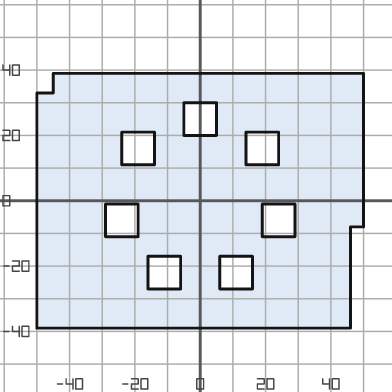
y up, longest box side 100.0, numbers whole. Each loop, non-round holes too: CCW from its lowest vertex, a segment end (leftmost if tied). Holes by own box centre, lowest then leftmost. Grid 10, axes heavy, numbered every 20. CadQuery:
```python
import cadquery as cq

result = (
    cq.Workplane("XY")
    .moveTo(-50.0, -39.0)
    .lineTo(46.0, -39.0)
    .lineTo(46.0, -8.0)
    .lineTo(50.0, -8.0)
    .lineTo(50.0, 39.0)
    .lineTo(-45.0, 39.0)
    .lineTo(-45.0, 33.0)
    .lineTo(-50.0, 33.0)
    .close()
    .moveTo(-16.0, -27.0)
    .lineTo(-6.0, -27.0)
    .lineTo(-6.0, -17.0)
    .lineTo(-16.0, -17.0)
    .close()
    .moveTo(6.0, -27.0)
    .lineTo(16.0, -27.0)
    .lineTo(16.0, -17.0)
    .lineTo(6.0, -17.0)
    .close()
    .moveTo(-29.0, -11.0)
    .lineTo(-19.0, -11.0)
    .lineTo(-19.0, -1.0)
    .lineTo(-29.0, -1.0)
    .close()
    .moveTo(19.0, -11.0)
    .lineTo(29.0, -11.0)
    .lineTo(29.0, -1.0)
    .lineTo(19.0, -1.0)
    .close()
    .moveTo(-24.0, 11.0)
    .lineTo(-14.0, 11.0)
    .lineTo(-14.0, 21.0)
    .lineTo(-24.0, 21.0)
    .close()
    .moveTo(14.0, 11.0)
    .lineTo(24.0, 11.0)
    .lineTo(24.0, 21.0)
    .lineTo(14.0, 21.0)
    .close()
    .moveTo(-5.0, 20.0)
    .lineTo(5.0, 20.0)
    .lineTo(5.0, 30.0)
    .lineTo(-5.0, 30.0)
    .close()
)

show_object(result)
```